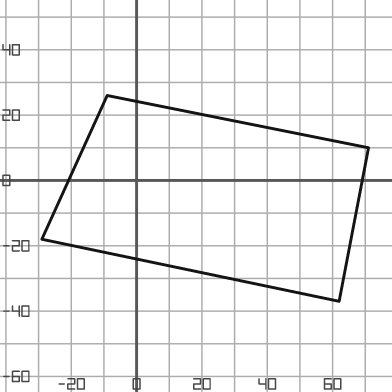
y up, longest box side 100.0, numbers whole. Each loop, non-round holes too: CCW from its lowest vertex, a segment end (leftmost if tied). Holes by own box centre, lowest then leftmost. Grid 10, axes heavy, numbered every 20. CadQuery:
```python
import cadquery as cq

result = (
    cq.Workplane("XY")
    .moveTo(62.0, -37.0)
    .lineTo(71.0, 10.0)
    .lineTo(-9.0, 26.0)
    .lineTo(-29.0, -18.0)
    .close()
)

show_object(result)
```